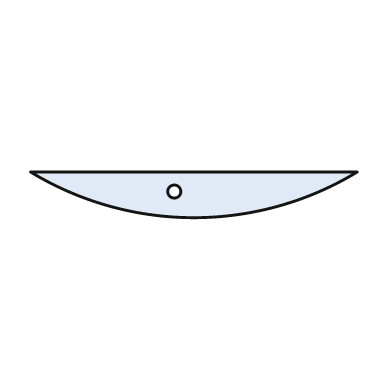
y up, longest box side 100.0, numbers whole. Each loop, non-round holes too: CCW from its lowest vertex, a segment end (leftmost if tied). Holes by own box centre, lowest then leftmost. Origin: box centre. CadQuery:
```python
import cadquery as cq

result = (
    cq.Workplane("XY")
    .moveTo(-50.0, 7.0)
    .threePointArc((0.0, -7.0), (50.0, 7.0))
    .close()
    .moveTo(-6.0, 1.0)
    .circle(2.0)
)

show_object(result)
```